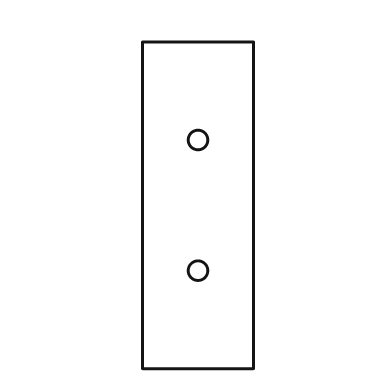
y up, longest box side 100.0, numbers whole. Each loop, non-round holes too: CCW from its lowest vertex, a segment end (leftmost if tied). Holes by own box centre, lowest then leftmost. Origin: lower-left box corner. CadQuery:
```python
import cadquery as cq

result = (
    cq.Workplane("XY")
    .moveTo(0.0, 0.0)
    .lineTo(34.0, 0.0)
    .lineTo(34.0, 100.0)
    .lineTo(0.0, 100.0)
    .close()
    .moveTo(17.0, 30.0)
    .circle(3.0)
    .moveTo(17.0, 70.0)
    .circle(3.0)
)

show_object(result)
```